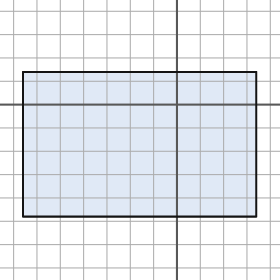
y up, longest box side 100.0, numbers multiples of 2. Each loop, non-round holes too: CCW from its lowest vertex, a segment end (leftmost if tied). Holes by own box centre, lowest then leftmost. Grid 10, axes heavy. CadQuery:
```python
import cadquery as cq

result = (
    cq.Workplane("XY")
    .moveTo(-66.0, -48.0)
    .lineTo(34.0, -48.0)
    .lineTo(34.0, 14.0)
    .lineTo(-66.0, 14.0)
    .close()
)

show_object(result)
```